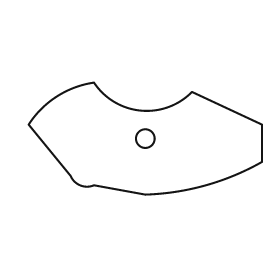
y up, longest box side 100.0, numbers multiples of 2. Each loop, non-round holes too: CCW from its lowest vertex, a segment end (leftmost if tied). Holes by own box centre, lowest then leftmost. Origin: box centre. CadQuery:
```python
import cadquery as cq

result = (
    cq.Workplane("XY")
    .moveTo(0.0, -24.0)
    .threePointArc((26.0, -20.0), (50.0, -10.0))
    .lineTo(50.0, 6.0)
    .lineTo(20.0, 20.0)
    .threePointArc((-2.0, 12.0), (-22.0, 24.0))
    .threePointArc((-38.0, 18.0), (-50.0, 6.0))
    .lineTo(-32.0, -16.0)
    .threePointArc((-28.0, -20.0), (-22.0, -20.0))
    .close()
    .moveTo(0.0, 0.0)
    .circle(4.0)
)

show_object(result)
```